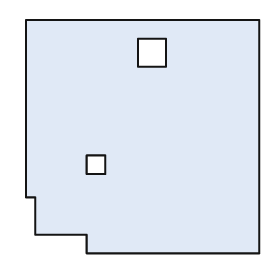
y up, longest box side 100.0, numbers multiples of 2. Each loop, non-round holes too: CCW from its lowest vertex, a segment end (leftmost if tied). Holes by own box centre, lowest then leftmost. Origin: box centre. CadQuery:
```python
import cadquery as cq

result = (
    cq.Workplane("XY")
    .moveTo(-24.0, -50.0)
    .lineTo(50.0, -50.0)
    .lineTo(50.0, 50.0)
    .lineTo(-50.0, 50.0)
    .lineTo(-50.0, -26.0)
    .lineTo(-46.0, -26.0)
    .lineTo(-46.0, -42.0)
    .lineTo(-24.0, -42.0)
    .close()
    .moveTo(-24.0, -16.0)
    .lineTo(-16.0, -16.0)
    .lineTo(-16.0, -8.0)
    .lineTo(-24.0, -8.0)
    .close()
    .moveTo(-2.0, 30.0)
    .lineTo(10.0, 30.0)
    .lineTo(10.0, 42.0)
    .lineTo(-2.0, 42.0)
    .close()
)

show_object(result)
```